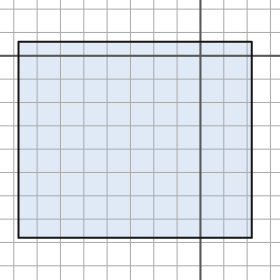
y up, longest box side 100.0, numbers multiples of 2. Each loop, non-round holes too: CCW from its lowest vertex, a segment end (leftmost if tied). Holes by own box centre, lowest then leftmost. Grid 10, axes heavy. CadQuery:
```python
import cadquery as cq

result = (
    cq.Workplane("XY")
    .moveTo(-78.0, -78.0)
    .lineTo(22.0, -78.0)
    .lineTo(22.0, 6.0)
    .lineTo(-78.0, 6.0)
    .close()
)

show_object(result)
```